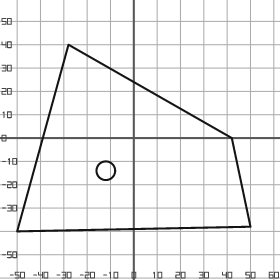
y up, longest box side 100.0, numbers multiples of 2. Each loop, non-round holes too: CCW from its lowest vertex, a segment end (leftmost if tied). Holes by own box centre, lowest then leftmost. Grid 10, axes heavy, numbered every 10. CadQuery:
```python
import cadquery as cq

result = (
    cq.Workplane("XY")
    .moveTo(-50.0, -40.0)
    .lineTo(50.0, -38.0)
    .lineTo(42.0, 0.0)
    .lineTo(-28.0, 40.0)
    .close()
    .moveTo(-12.0, -14.0)
    .circle(4.0)
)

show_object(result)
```